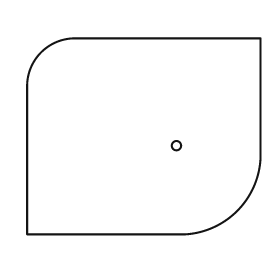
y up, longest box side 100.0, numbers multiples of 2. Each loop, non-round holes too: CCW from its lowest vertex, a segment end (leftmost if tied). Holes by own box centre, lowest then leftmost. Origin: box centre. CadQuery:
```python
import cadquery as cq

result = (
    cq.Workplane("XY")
    .moveTo(-50.0, -42.0)
    .lineTo(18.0, -42.0)
    .threePointArc((40.0, -32.0), (50.0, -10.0))
    .lineTo(50.0, 42.0)
    .lineTo(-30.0, 42.0)
    .threePointArc((-44.0, 36.0), (-50.0, 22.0))
    .close()
    .moveTo(14.0, -4.0)
    .circle(2.0)
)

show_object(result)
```